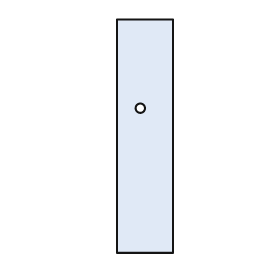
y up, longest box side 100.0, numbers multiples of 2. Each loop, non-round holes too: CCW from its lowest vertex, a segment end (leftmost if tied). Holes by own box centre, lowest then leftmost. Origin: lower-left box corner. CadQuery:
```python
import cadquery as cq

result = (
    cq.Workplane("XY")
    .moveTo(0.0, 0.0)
    .lineTo(24.0, 0.0)
    .lineTo(24.0, 100.0)
    .lineTo(0.0, 100.0)
    .close()
    .moveTo(10.0, 62.0)
    .circle(2.0)
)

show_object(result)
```